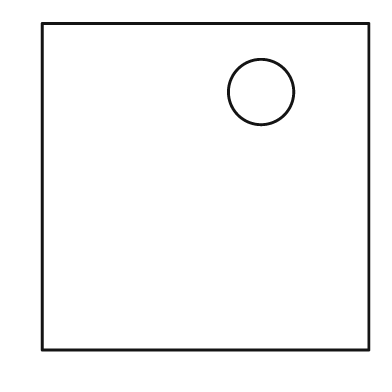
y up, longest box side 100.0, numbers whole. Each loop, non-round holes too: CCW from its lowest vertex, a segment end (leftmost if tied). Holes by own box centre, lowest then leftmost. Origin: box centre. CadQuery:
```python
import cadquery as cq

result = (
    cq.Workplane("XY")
    .moveTo(-50.0, -50.0)
    .lineTo(50.0, -50.0)
    .lineTo(50.0, 50.0)
    .lineTo(-50.0, 50.0)
    .close()
    .moveTo(17.0, 29.0)
    .circle(10.0)
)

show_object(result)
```